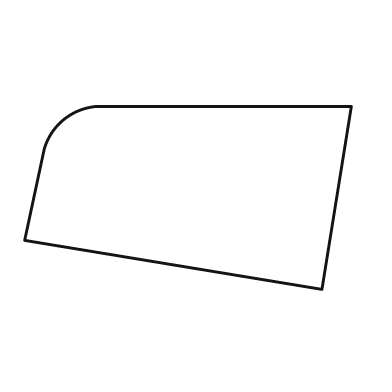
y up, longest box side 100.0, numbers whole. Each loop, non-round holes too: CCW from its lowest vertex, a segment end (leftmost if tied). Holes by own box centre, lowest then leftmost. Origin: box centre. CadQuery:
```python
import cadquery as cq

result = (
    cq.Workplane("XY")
    .moveTo(41.0, -28.0)
    .lineTo(50.0, 28.0)
    .lineTo(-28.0, 28.0)
    .threePointArc((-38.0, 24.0), (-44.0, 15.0))
    .lineTo(-50.0, -13.0)
    .close()
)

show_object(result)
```